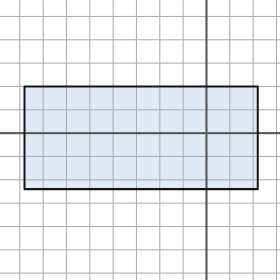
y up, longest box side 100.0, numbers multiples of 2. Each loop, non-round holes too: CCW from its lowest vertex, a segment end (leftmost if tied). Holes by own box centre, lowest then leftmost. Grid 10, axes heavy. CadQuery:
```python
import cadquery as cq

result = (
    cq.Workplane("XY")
    .moveTo(-78.0, -24.0)
    .lineTo(22.0, -24.0)
    .lineTo(22.0, 20.0)
    .lineTo(-78.0, 20.0)
    .close()
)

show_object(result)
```